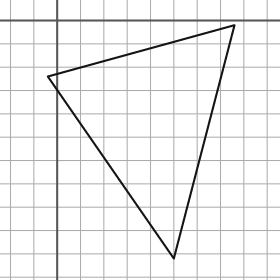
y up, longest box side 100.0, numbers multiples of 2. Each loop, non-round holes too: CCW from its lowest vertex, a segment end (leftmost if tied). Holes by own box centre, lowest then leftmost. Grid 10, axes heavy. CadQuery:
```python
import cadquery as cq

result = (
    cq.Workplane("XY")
    .moveTo(50.0, -102.0)
    .lineTo(76.0, -2.0)
    .lineTo(-4.0, -24.0)
    .close()
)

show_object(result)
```